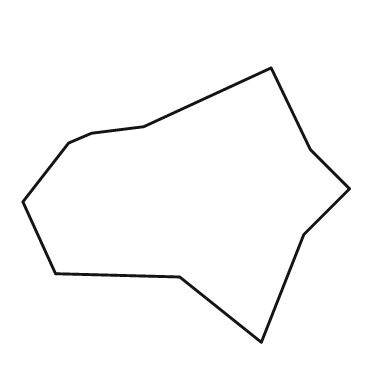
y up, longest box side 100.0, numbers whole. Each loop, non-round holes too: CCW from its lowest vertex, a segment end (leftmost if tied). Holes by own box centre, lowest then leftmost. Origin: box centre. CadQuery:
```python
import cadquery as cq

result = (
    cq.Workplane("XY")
    .moveTo(23.0, -42.0)
    .lineTo(36.0, -9.0)
    .lineTo(50.0, 5.0)
    .lineTo(38.0, 17.0)
    .lineTo(26.0, 42.0)
    .lineTo(-13.0, 24.0)
    .lineTo(-29.0, 22.0)
    .lineTo(-36.0, 19.0)
    .lineTo(-50.0, 1.0)
    .lineTo(-40.0, -21.0)
    .lineTo(-2.0, -22.0)
    .close()
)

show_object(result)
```